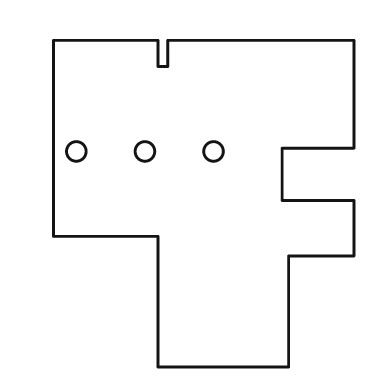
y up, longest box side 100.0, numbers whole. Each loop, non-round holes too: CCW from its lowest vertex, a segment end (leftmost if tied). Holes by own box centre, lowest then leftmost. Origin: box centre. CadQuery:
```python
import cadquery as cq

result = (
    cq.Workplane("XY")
    .moveTo(-14.0, -50.0)
    .lineTo(26.0, -50.0)
    .lineTo(26.0, -16.0)
    .lineTo(46.0, -16.0)
    .lineTo(46.0, 1.0)
    .lineTo(24.0, 1.0)
    .lineTo(24.0, 17.0)
    .lineTo(46.0, 17.0)
    .lineTo(46.0, 50.0)
    .lineTo(-11.0, 50.0)
    .lineTo(-11.0, 42.0)
    .lineTo(-14.0, 42.0)
    .lineTo(-14.0, 50.0)
    .lineTo(-46.0, 50.0)
    .lineTo(-46.0, -10.0)
    .lineTo(-14.0, -10.0)
    .close()
    .moveTo(-39.0, 16.0)
    .circle(3.0)
    .moveTo(-18.0, 16.0)
    .circle(3.0)
    .moveTo(3.0, 16.0)
    .circle(3.0)
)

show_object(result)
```